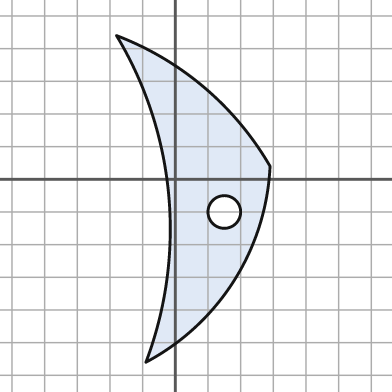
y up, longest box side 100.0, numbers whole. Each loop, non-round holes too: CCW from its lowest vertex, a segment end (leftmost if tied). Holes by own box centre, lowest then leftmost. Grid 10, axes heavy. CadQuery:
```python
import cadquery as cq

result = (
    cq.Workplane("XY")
    .moveTo(-9.0, -56.0)
    .threePointArc((18.0, -31.0), (29.0, 4.0))
    .threePointArc((9.0, 28.0), (-18.0, 44.0))
    .threePointArc((-2.0, -5.0), (-9.0, -56.0))
    .close()
    .moveTo(15.0, -10.0)
    .circle(5.0)
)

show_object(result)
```